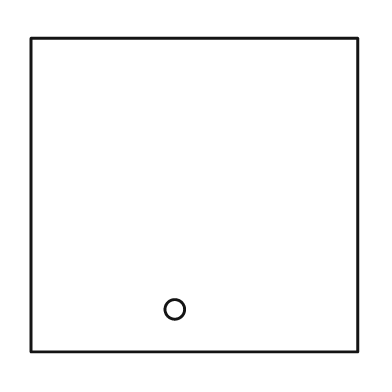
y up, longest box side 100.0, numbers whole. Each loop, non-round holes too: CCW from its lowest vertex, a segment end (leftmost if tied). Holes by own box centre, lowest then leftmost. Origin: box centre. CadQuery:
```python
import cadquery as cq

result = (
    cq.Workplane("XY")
    .moveTo(-50.0, -48.0)
    .lineTo(50.0, -48.0)
    .lineTo(50.0, 48.0)
    .lineTo(-50.0, 48.0)
    .close()
    .moveTo(-6.0, -35.0)
    .circle(3.0)
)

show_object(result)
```